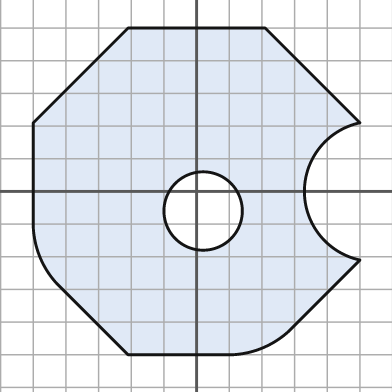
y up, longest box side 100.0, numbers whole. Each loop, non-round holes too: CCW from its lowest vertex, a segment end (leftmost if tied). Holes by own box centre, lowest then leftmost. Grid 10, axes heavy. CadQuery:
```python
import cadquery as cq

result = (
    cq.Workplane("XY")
    .moveTo(-21.0, -50.0)
    .lineTo(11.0, -50.0)
    .threePointArc((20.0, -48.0), (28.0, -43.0))
    .lineTo(50.0, -21.0)
    .threePointArc((33.0, 0.0), (50.0, 21.0))
    .lineTo(21.0, 50.0)
    .lineTo(-21.0, 50.0)
    .lineTo(-50.0, 21.0)
    .lineTo(-50.0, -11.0)
    .threePointArc((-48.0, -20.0), (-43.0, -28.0))
    .close()
    .moveTo(2.0, -6.0)
    .circle(12.0)
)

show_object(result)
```